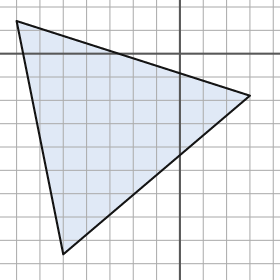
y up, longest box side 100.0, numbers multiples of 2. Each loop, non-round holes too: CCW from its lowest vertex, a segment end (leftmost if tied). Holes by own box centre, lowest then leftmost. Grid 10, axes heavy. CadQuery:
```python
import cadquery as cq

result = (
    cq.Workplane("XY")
    .moveTo(-50.0, -86.0)
    .lineTo(30.0, -18.0)
    .lineTo(-70.0, 14.0)
    .close()
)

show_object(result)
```